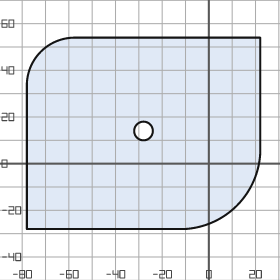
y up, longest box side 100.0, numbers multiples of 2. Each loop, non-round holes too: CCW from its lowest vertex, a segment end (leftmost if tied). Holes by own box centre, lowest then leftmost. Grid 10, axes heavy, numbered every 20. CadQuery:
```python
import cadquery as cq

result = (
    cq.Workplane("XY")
    .moveTo(-78.0, -28.0)
    .lineTo(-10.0, -28.0)
    .threePointArc((12.0, -18.0), (22.0, 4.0))
    .lineTo(22.0, 54.0)
    .lineTo(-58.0, 54.0)
    .threePointArc((-72.0, 48.0), (-78.0, 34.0))
    .close()
    .moveTo(-28.0, 14.0)
    .circle(4.0)
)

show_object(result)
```